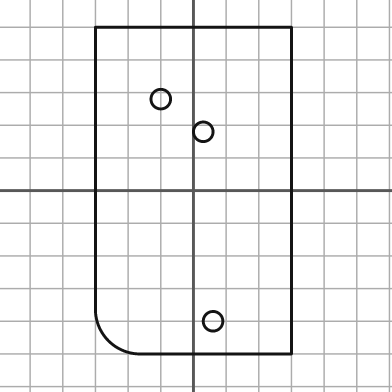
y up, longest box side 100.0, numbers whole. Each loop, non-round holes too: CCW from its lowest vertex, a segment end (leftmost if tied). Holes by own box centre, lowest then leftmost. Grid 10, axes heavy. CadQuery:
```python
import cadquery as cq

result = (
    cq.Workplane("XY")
    .moveTo(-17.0, -50.0)
    .lineTo(30.0, -50.0)
    .lineTo(30.0, 50.0)
    .lineTo(-30.0, 50.0)
    .lineTo(-30.0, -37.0)
    .threePointArc((-26.0, -46.0), (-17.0, -50.0))
    .close()
    .moveTo(6.0, -40.0)
    .circle(3.0)
    .moveTo(3.0, 18.0)
    .circle(3.0)
    .moveTo(-10.0, 28.0)
    .circle(3.0)
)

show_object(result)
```